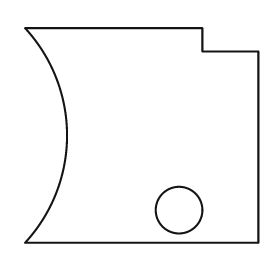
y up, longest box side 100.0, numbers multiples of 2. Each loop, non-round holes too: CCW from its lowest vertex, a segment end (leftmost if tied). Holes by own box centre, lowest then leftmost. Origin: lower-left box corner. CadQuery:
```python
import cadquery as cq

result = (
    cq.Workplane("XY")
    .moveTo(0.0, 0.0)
    .lineTo(100.0, 0.0)
    .lineTo(100.0, 82.0)
    .lineTo(76.0, 82.0)
    .lineTo(76.0, 92.0)
    .lineTo(0.0, 92.0)
    .threePointArc((18.0, 46.0), (0.0, 0.0))
    .close()
    .moveTo(66.0, 14.0)
    .circle(10.0)
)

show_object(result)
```